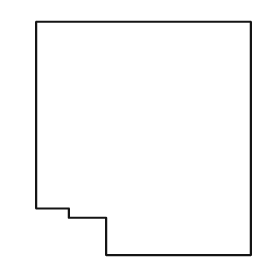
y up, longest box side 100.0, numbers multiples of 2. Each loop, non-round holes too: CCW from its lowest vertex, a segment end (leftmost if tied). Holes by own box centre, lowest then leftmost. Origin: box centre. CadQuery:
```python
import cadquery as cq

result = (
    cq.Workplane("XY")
    .moveTo(-16.0, -50.0)
    .lineTo(46.0, -50.0)
    .lineTo(46.0, 50.0)
    .lineTo(-46.0, 50.0)
    .lineTo(-46.0, -30.0)
    .lineTo(-32.0, -30.0)
    .lineTo(-32.0, -34.0)
    .lineTo(-16.0, -34.0)
    .close()
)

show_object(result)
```